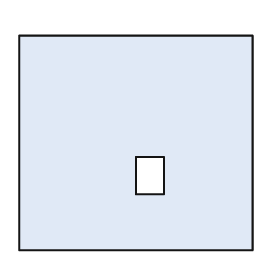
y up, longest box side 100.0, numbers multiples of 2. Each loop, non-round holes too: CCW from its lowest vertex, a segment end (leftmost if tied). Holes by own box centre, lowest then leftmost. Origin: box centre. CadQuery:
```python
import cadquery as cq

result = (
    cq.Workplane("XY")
    .moveTo(-50.0, -46.0)
    .lineTo(50.0, -46.0)
    .lineTo(50.0, 46.0)
    .lineTo(-50.0, 46.0)
    .close()
    .moveTo(0.0, -22.0)
    .lineTo(12.0, -22.0)
    .lineTo(12.0, -6.0)
    .lineTo(0.0, -6.0)
    .close()
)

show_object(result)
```